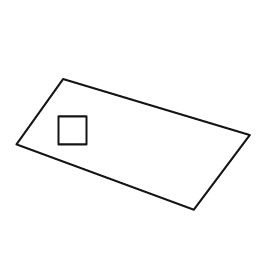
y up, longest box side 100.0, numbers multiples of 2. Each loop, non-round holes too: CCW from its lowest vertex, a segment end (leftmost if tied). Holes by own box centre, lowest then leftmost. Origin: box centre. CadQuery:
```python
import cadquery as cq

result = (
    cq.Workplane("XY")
    .moveTo(26.0, -28.0)
    .lineTo(50.0, 4.0)
    .lineTo(-30.0, 28.0)
    .lineTo(-50.0, 0.0)
    .close()
    .moveTo(-32.0, 0.0)
    .lineTo(-20.0, 0.0)
    .lineTo(-20.0, 12.0)
    .lineTo(-32.0, 12.0)
    .close()
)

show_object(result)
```